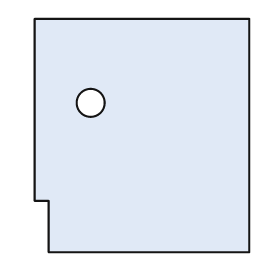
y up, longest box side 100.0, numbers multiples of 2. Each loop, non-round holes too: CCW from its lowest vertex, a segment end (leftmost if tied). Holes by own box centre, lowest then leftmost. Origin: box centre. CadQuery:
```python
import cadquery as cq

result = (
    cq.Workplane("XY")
    .moveTo(-40.0, -50.0)
    .lineTo(46.0, -50.0)
    .lineTo(46.0, 50.0)
    .lineTo(-46.0, 50.0)
    .lineTo(-46.0, -28.0)
    .lineTo(-40.0, -28.0)
    .close()
    .moveTo(-22.0, 14.0)
    .circle(6.0)
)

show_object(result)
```